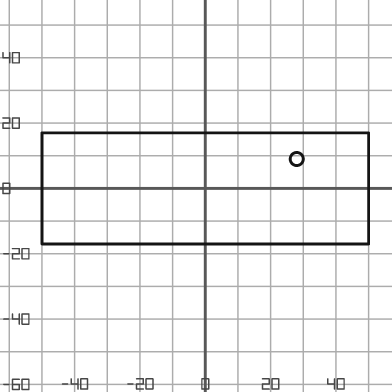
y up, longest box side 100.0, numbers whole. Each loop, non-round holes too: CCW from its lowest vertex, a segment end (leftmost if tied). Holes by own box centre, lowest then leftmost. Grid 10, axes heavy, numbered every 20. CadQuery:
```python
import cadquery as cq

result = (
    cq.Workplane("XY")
    .moveTo(-50.0, -17.0)
    .lineTo(50.0, -17.0)
    .lineTo(50.0, 17.0)
    .lineTo(-50.0, 17.0)
    .close()
    .moveTo(28.0, 9.0)
    .circle(2.0)
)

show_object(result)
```